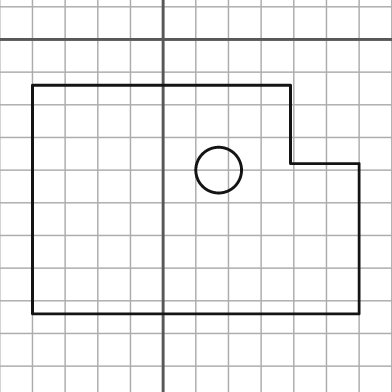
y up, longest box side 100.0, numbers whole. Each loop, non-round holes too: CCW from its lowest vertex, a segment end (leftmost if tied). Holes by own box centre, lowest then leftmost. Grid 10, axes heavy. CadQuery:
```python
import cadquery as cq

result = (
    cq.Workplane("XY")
    .moveTo(-40.0, -84.0)
    .lineTo(60.0, -84.0)
    .lineTo(60.0, -38.0)
    .lineTo(39.0, -38.0)
    .lineTo(39.0, -14.0)
    .lineTo(-40.0, -14.0)
    .close()
    .moveTo(17.0, -40.0)
    .circle(7.0)
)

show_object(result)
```